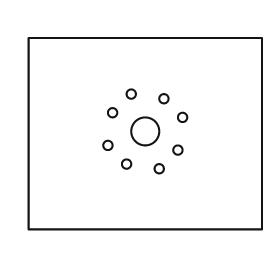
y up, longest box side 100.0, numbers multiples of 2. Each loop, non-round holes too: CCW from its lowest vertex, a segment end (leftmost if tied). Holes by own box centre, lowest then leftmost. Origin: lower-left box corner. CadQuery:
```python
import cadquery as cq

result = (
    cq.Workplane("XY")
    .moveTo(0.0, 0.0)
    .lineTo(100.0, 0.0)
    .lineTo(100.0, 82.0)
    .lineTo(0.0, 82.0)
    .close()
    .moveTo(56.0, 26.0)
    .circle(2.0)
    .moveTo(42.0, 28.0)
    .circle(2.0)
    .moveTo(64.0, 34.0)
    .circle(2.0)
    .moveTo(34.0, 36.0)
    .circle(2.0)
    .moveTo(50.0, 42.0)
    .circle(6.0)
    .moveTo(66.0, 48.0)
    .circle(2.0)
    .moveTo(36.0, 50.0)
    .circle(2.0)
    .moveTo(58.0, 56.0)
    .circle(2.0)
    .moveTo(44.0, 58.0)
    .circle(2.0)
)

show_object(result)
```